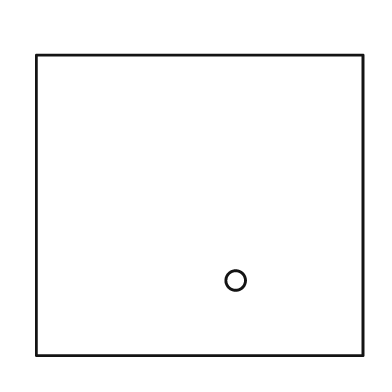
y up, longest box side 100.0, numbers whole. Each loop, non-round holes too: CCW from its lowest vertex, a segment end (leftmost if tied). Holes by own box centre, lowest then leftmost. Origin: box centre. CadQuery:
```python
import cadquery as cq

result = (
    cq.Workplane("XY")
    .moveTo(-50.0, -46.0)
    .lineTo(50.0, -46.0)
    .lineTo(50.0, 46.0)
    .lineTo(-50.0, 46.0)
    .close()
    .moveTo(11.0, -23.0)
    .circle(3.0)
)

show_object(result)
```